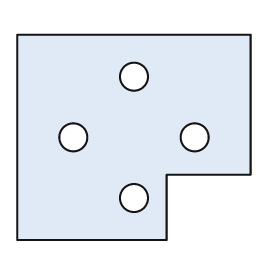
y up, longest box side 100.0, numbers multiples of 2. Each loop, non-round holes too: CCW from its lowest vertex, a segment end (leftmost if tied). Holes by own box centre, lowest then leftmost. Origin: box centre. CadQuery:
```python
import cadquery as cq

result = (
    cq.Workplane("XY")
    .moveTo(-50.0, -44.0)
    .lineTo(14.0, -44.0)
    .lineTo(14.0, -16.0)
    .lineTo(50.0, -16.0)
    .lineTo(50.0, 44.0)
    .lineTo(-50.0, 44.0)
    .close()
    .moveTo(0.0, -26.0)
    .circle(6.0)
    .moveTo(-26.0, 0.0)
    .circle(6.0)
    .moveTo(26.0, 0.0)
    .circle(6.0)
    .moveTo(0.0, 26.0)
    .circle(6.0)
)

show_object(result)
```